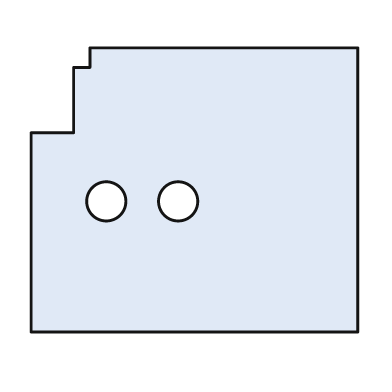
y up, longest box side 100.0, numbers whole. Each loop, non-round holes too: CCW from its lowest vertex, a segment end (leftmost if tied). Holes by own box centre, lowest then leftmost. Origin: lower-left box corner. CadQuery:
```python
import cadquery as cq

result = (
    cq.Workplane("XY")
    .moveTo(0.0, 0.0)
    .lineTo(100.0, 0.0)
    .lineTo(100.0, 87.0)
    .lineTo(18.0, 87.0)
    .lineTo(18.0, 81.0)
    .lineTo(13.0, 81.0)
    .lineTo(13.0, 61.0)
    .lineTo(0.0, 61.0)
    .close()
    .moveTo(23.0, 40.0)
    .circle(6.0)
    .moveTo(45.0, 40.0)
    .circle(6.0)
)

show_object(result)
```